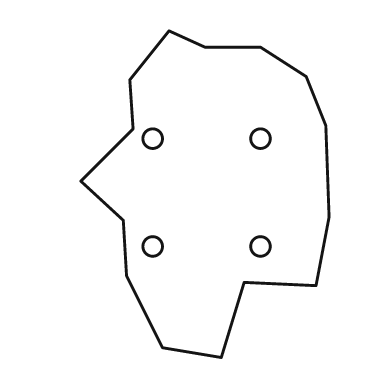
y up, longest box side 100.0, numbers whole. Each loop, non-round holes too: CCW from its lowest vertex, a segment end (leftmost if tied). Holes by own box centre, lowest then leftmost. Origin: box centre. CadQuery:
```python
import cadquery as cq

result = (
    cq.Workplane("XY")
    .moveTo(5.0, -50.0)
    .lineTo(12.0, -27.0)
    .lineTo(34.0, -28.0)
    .lineTo(38.0, -7.0)
    .lineTo(37.0, 21.0)
    .lineTo(31.0, 36.0)
    .lineTo(17.0, 45.0)
    .lineTo(0.0, 45.0)
    .lineTo(-11.0, 50.0)
    .lineTo(-23.0, 35.0)
    .lineTo(-22.0, 20.0)
    .lineTo(-38.0, 4.0)
    .lineTo(-25.0, -8.0)
    .lineTo(-24.0, -25.0)
    .lineTo(-13.0, -47.0)
    .close()
    .moveTo(-16.0, -16.0)
    .circle(3.0)
    .moveTo(17.0, -16.0)
    .circle(3.0)
    .moveTo(-16.0, 17.0)
    .circle(3.0)
    .moveTo(17.0, 17.0)
    .circle(3.0)
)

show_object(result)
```